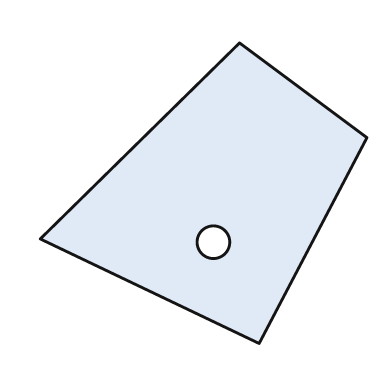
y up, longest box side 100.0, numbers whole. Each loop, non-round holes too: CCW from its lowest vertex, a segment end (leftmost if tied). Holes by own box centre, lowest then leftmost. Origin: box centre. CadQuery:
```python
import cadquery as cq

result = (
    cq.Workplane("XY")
    .moveTo(17.0, -46.0)
    .lineTo(50.0, 17.0)
    .lineTo(11.0, 46.0)
    .lineTo(-50.0, -14.0)
    .close()
    .moveTo(3.0, -15.0)
    .circle(5.0)
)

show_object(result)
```